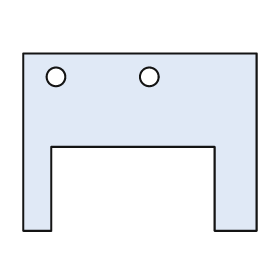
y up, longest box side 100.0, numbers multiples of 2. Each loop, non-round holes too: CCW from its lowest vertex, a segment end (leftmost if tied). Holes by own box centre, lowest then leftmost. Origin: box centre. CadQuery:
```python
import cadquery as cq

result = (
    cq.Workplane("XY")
    .moveTo(-50.0, -38.0)
    .lineTo(-38.0, -38.0)
    .lineTo(-38.0, -2.0)
    .lineTo(32.0, -2.0)
    .lineTo(32.0, -38.0)
    .lineTo(50.0, -38.0)
    .lineTo(50.0, 38.0)
    .lineTo(-50.0, 38.0)
    .close()
    .moveTo(-36.0, 28.0)
    .circle(4.0)
    .moveTo(4.0, 28.0)
    .circle(4.0)
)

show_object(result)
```